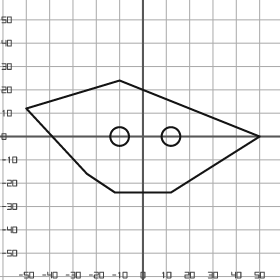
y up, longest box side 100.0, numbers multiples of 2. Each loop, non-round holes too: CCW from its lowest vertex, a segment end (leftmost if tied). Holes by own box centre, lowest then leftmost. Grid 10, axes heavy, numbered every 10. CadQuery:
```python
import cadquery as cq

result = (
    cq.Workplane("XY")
    .moveTo(-12.0, -24.0)
    .lineTo(12.0, -24.0)
    .lineTo(50.0, 0.0)
    .lineTo(-10.0, 24.0)
    .lineTo(-50.0, 12.0)
    .lineTo(-24.0, -16.0)
    .close()
    .moveTo(-10.0, 0.0)
    .circle(4.0)
    .moveTo(12.0, 0.0)
    .circle(4.0)
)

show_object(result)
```